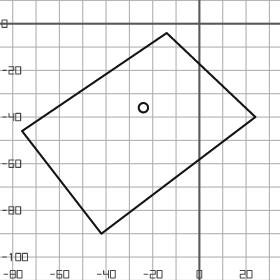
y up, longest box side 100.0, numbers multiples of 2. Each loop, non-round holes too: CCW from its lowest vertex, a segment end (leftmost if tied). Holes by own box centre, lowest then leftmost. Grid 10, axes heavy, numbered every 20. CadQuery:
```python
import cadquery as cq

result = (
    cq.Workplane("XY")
    .moveTo(-42.0, -90.0)
    .lineTo(24.0, -40.0)
    .lineTo(-14.0, -4.0)
    .lineTo(-76.0, -46.0)
    .close()
    .moveTo(-24.0, -36.0)
    .circle(2.0)
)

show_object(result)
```